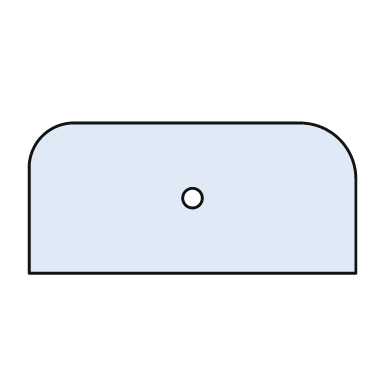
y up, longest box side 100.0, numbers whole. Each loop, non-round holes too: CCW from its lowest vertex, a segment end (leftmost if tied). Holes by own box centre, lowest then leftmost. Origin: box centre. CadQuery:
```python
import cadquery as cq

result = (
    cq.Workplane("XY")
    .moveTo(-50.0, -23.0)
    .lineTo(50.0, -23.0)
    .lineTo(50.0, 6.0)
    .threePointArc((45.0, 18.0), (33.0, 23.0))
    .lineTo(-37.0, 23.0)
    .threePointArc((-46.0, 19.0), (-50.0, 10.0))
    .close()
    .moveTo(0.0, 0.0)
    .circle(3.0)
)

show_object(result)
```